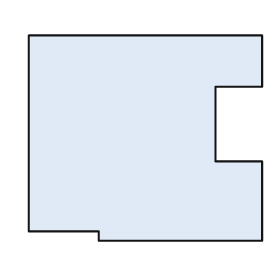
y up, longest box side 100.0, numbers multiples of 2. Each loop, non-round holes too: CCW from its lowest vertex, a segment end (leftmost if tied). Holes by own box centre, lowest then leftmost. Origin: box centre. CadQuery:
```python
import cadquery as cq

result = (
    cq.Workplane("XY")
    .moveTo(-20.0, -44.0)
    .lineTo(50.0, -44.0)
    .lineTo(50.0, -10.0)
    .lineTo(30.0, -10.0)
    .lineTo(30.0, 22.0)
    .lineTo(50.0, 22.0)
    .lineTo(50.0, 44.0)
    .lineTo(-50.0, 44.0)
    .lineTo(-50.0, -40.0)
    .lineTo(-20.0, -40.0)
    .close()
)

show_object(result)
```